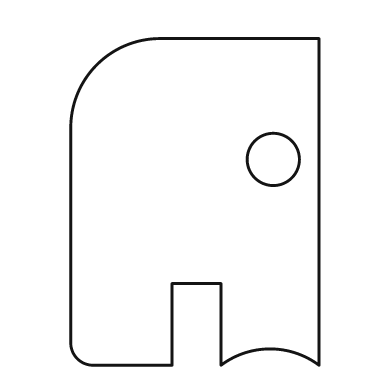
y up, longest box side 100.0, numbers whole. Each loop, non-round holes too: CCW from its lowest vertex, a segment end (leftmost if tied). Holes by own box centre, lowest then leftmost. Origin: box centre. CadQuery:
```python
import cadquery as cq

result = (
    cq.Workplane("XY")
    .moveTo(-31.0, -50.0)
    .lineTo(-7.0, -50.0)
    .lineTo(-7.0, -25.0)
    .lineTo(8.0, -25.0)
    .lineTo(8.0, -50.0)
    .threePointArc((23.0, -45.0), (38.0, -50.0))
    .lineTo(38.0, 50.0)
    .lineTo(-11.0, 50.0)
    .threePointArc((-30.0, 42.0), (-38.0, 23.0))
    .lineTo(-38.0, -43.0)
    .threePointArc((-36.0, -48.0), (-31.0, -50.0))
    .close()
    .moveTo(24.0, 13.0)
    .circle(8.0)
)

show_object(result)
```